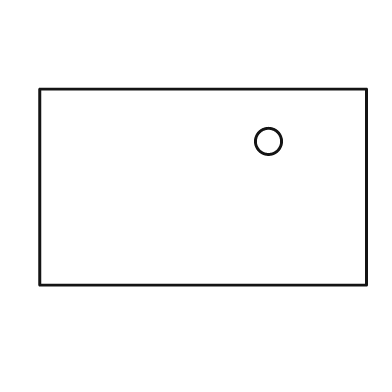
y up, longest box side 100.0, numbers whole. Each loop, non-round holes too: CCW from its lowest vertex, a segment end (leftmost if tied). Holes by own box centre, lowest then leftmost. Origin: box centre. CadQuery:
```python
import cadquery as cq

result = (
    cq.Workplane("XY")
    .moveTo(-50.0, -30.0)
    .lineTo(50.0, -30.0)
    .lineTo(50.0, 30.0)
    .lineTo(-50.0, 30.0)
    .close()
    .moveTo(20.0, 14.0)
    .circle(4.0)
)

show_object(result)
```